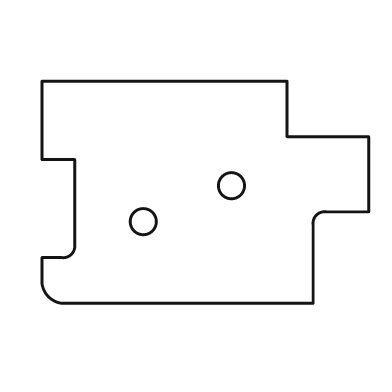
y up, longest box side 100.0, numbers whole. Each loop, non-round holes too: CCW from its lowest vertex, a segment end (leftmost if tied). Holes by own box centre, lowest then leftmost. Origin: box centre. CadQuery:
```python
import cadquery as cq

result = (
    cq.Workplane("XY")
    .moveTo(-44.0, -34.0)
    .lineTo(33.0, -34.0)
    .lineTo(33.0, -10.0)
    .threePointArc((34.0, -7.0), (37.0, -6.0))
    .lineTo(50.0, -6.0)
    .lineTo(50.0, 17.0)
    .lineTo(25.0, 17.0)
    .lineTo(25.0, 34.0)
    .lineTo(-50.0, 34.0)
    .lineTo(-50.0, 10.0)
    .lineTo(-40.0, 10.0)
    .lineTo(-40.0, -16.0)
    .threePointArc((-41.0, -19.0), (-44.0, -20.0))
    .lineTo(-50.0, -20.0)
    .lineTo(-50.0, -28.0)
    .threePointArc((-48.0, -32.0), (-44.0, -34.0))
    .close()
    .moveTo(-19.0, -9.0)
    .circle(4.0)
    .moveTo(8.0, 2.0)
    .circle(4.0)
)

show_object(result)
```